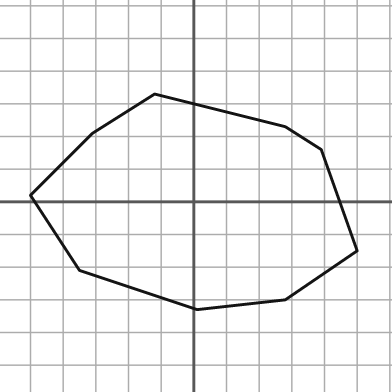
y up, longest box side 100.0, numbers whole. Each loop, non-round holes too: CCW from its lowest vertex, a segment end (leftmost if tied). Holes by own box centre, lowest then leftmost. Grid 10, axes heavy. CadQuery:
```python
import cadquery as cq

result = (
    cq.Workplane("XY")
    .moveTo(1.0, -33.0)
    .lineTo(28.0, -30.0)
    .lineTo(50.0, -15.0)
    .lineTo(39.0, 16.0)
    .lineTo(28.0, 23.0)
    .lineTo(-12.0, 33.0)
    .lineTo(-31.0, 21.0)
    .lineTo(-50.0, 2.0)
    .lineTo(-35.0, -21.0)
    .close()
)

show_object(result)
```